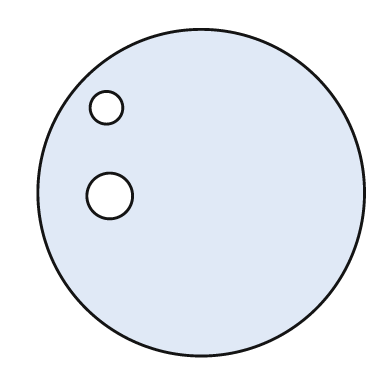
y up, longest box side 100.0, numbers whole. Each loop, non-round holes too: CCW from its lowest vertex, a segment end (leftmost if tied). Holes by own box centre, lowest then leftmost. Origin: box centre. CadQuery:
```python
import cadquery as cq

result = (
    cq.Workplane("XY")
    .moveTo(0.0, 0.0)
    .circle(50.0)
    .moveTo(-28.0, -1.0)
    .circle(7.0)
    .moveTo(-29.0, 26.0)
    .circle(5.0)
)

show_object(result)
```